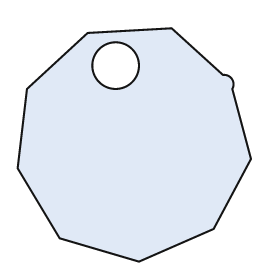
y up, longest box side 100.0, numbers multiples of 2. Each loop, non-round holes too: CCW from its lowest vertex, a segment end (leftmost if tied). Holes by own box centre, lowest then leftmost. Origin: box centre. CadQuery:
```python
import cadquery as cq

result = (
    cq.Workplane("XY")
    .moveTo(2.0, -50.0)
    .lineTo(34.0, -36.0)
    .lineTo(50.0, -6.0)
    .lineTo(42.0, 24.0)
    .threePointArc((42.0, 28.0), (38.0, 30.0))
    .lineTo(16.0, 50.0)
    .lineTo(-20.0, 48.0)
    .lineTo(-46.0, 24.0)
    .lineTo(-50.0, -10.0)
    .lineTo(-32.0, -40.0)
    .close()
    .moveTo(-8.0, 34.0)
    .circle(10.0)
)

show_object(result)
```